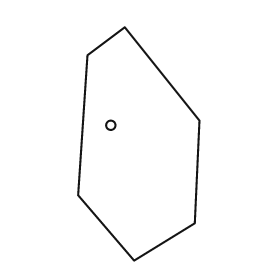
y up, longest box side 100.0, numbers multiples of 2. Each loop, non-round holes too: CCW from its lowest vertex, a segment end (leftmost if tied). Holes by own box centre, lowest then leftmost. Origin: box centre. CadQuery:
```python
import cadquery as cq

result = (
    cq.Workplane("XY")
    .moveTo(-2.0, -50.0)
    .lineTo(24.0, -34.0)
    .lineTo(26.0, 10.0)
    .lineTo(-6.0, 50.0)
    .lineTo(-22.0, 38.0)
    .lineTo(-26.0, -22.0)
    .close()
    .moveTo(-12.0, 8.0)
    .circle(2.0)
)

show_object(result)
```